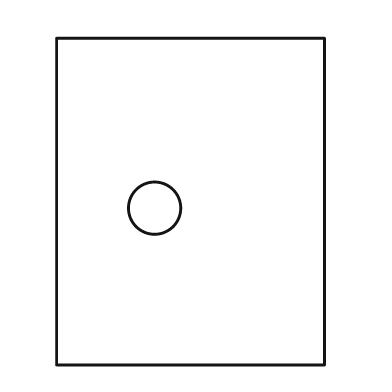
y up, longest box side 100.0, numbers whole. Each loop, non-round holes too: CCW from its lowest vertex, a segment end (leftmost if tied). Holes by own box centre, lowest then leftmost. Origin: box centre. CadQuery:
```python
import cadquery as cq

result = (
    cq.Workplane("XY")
    .moveTo(-41.0, -50.0)
    .lineTo(41.0, -50.0)
    .lineTo(41.0, 50.0)
    .lineTo(-41.0, 50.0)
    .close()
    .moveTo(-11.0, -2.0)
    .circle(8.0)
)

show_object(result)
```